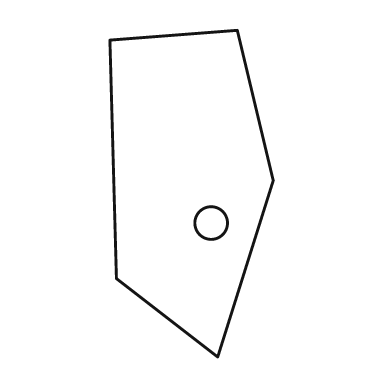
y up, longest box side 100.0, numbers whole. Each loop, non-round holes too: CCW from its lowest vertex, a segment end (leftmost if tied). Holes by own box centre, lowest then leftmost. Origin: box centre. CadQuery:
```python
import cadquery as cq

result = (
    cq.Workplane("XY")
    .moveTo(8.0, -50.0)
    .lineTo(25.0, 4.0)
    .lineTo(14.0, 50.0)
    .lineTo(-25.0, 47.0)
    .lineTo(-23.0, -26.0)
    .close()
    .moveTo(6.0, -9.0)
    .circle(5.0)
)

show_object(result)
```